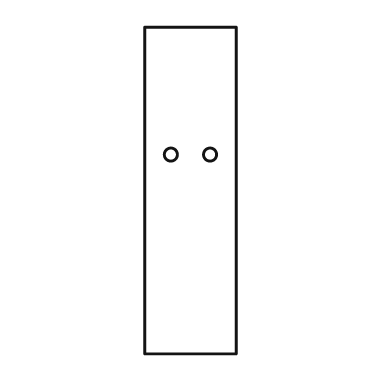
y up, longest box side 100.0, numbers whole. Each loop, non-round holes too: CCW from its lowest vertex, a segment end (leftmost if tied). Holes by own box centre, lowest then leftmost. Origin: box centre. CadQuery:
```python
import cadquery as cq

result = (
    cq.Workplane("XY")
    .moveTo(-14.0, -50.0)
    .lineTo(14.0, -50.0)
    .lineTo(14.0, 50.0)
    .lineTo(-14.0, 50.0)
    .close()
    .moveTo(-6.0, 11.0)
    .circle(2.0)
    .moveTo(6.0, 11.0)
    .circle(2.0)
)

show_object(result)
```